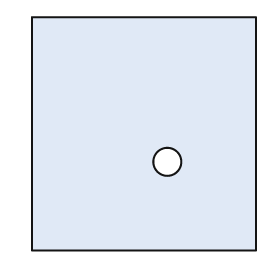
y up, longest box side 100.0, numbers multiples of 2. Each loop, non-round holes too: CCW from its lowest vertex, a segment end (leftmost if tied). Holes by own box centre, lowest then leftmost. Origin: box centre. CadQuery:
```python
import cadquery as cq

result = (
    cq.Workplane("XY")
    .moveTo(-48.0, -50.0)
    .lineTo(48.0, -50.0)
    .lineTo(48.0, 50.0)
    .lineTo(-48.0, 50.0)
    .close()
    .moveTo(10.0, -12.0)
    .circle(6.0)
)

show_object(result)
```